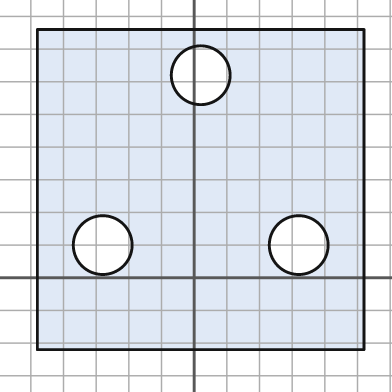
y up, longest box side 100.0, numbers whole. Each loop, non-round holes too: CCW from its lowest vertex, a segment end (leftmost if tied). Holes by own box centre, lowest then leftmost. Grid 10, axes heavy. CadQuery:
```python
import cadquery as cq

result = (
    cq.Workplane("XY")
    .moveTo(-48.0, -22.0)
    .lineTo(52.0, -22.0)
    .lineTo(52.0, 76.0)
    .lineTo(-48.0, 76.0)
    .close()
    .moveTo(-28.0, 10.0)
    .circle(9.0)
    .moveTo(32.0, 10.0)
    .circle(9.0)
    .moveTo(2.0, 62.0)
    .circle(9.0)
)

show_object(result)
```